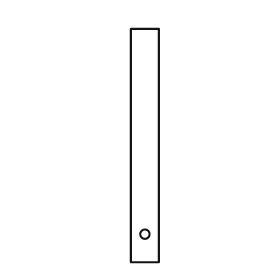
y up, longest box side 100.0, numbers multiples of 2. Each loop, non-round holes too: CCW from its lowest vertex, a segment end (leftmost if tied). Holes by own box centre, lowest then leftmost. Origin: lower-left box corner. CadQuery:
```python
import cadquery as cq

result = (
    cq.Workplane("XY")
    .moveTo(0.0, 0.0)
    .lineTo(12.0, 0.0)
    .lineTo(12.0, 100.0)
    .lineTo(0.0, 100.0)
    .close()
    .moveTo(6.0, 12.0)
    .circle(2.0)
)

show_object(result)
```